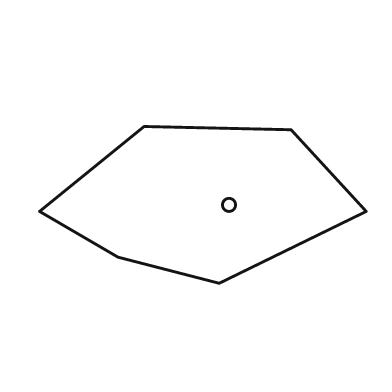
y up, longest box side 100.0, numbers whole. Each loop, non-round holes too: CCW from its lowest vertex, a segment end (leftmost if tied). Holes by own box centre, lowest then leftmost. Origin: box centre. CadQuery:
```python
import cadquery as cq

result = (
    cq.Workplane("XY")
    .moveTo(5.0, -24.0)
    .lineTo(50.0, -2.0)
    .lineTo(27.0, 23.0)
    .lineTo(-18.0, 24.0)
    .lineTo(-50.0, -2.0)
    .lineTo(-26.0, -16.0)
    .close()
    .moveTo(8.0, 0.0)
    .circle(2.0)
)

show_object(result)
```